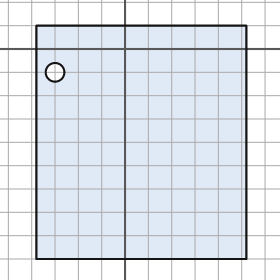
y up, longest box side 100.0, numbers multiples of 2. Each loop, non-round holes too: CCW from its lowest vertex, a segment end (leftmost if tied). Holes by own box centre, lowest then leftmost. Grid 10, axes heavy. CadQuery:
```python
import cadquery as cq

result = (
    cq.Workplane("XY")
    .moveTo(-38.0, -90.0)
    .lineTo(52.0, -90.0)
    .lineTo(52.0, 10.0)
    .lineTo(-38.0, 10.0)
    .close()
    .moveTo(-30.0, -10.0)
    .circle(4.0)
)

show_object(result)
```